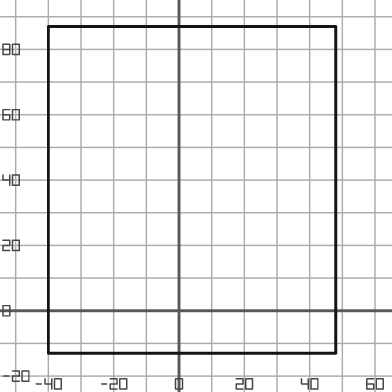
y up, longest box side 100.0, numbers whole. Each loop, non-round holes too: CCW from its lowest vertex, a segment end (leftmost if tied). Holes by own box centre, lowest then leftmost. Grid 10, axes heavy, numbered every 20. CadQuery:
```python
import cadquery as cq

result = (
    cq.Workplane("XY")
    .moveTo(-40.0, -13.0)
    .lineTo(48.0, -13.0)
    .lineTo(48.0, 87.0)
    .lineTo(-40.0, 87.0)
    .close()
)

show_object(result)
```